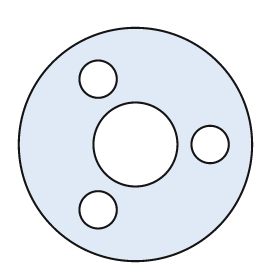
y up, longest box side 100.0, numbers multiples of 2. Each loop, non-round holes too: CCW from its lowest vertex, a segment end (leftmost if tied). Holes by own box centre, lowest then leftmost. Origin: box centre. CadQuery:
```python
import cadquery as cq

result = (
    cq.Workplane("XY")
    .moveTo(0.0, 0.0)
    .circle(50.0)
    .moveTo(-16.0, -28.0)
    .circle(8.0)
    .moveTo(0.0, 0.0)
    .circle(18.0)
    .moveTo(32.0, 0.0)
    .circle(8.0)
    .moveTo(-16.0, 28.0)
    .circle(8.0)
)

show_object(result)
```